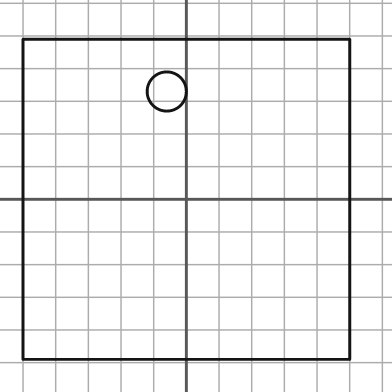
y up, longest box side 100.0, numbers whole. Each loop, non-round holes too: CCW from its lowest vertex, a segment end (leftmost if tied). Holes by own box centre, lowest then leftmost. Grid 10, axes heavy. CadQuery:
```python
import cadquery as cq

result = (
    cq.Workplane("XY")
    .moveTo(-50.0, -49.0)
    .lineTo(50.0, -49.0)
    .lineTo(50.0, 49.0)
    .lineTo(-50.0, 49.0)
    .close()
    .moveTo(-6.0, 33.0)
    .circle(6.0)
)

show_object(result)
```